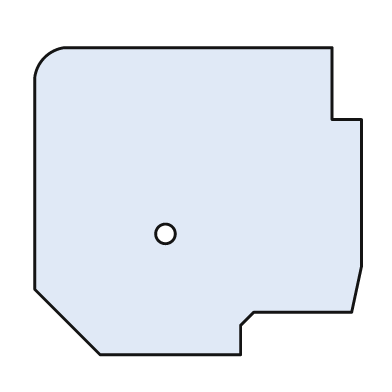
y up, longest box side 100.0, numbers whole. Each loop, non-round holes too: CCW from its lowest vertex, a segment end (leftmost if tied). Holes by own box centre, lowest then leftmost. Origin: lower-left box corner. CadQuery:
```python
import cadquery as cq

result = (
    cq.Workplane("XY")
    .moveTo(20.0, 0.0)
    .lineTo(63.0, 0.0)
    .lineTo(63.0, 9.0)
    .lineTo(67.0, 13.0)
    .lineTo(97.0, 13.0)
    .lineTo(100.0, 27.0)
    .lineTo(100.0, 72.0)
    .lineTo(91.0, 72.0)
    .lineTo(91.0, 94.0)
    .lineTo(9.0, 94.0)
    .threePointArc((3.0, 91.0), (0.0, 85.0))
    .lineTo(0.0, 20.0)
    .close()
    .moveTo(40.0, 37.0)
    .circle(3.0)
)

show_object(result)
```